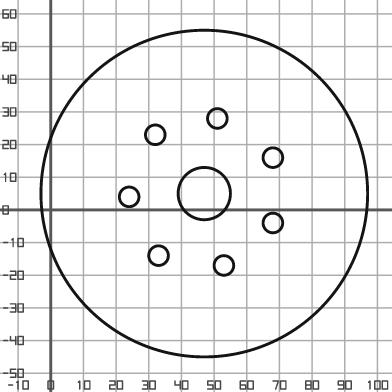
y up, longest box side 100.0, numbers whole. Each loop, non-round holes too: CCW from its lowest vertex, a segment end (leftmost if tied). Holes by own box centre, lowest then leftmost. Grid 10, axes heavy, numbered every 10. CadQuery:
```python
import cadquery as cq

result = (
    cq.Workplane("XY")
    .moveTo(47.0, 5.0)
    .circle(50.0)
    .moveTo(53.0, -17.0)
    .circle(3.0)
    .moveTo(33.0, -14.0)
    .circle(3.0)
    .moveTo(68.0, -4.0)
    .circle(3.0)
    .moveTo(24.0, 4.0)
    .circle(3.0)
    .moveTo(47.0, 5.0)
    .circle(8.0)
    .moveTo(68.0, 16.0)
    .circle(3.0)
    .moveTo(32.0, 23.0)
    .circle(3.0)
    .moveTo(51.0, 28.0)
    .circle(3.0)
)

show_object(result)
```